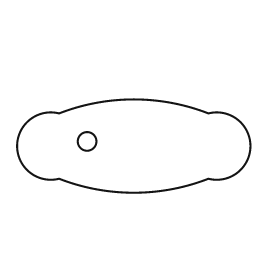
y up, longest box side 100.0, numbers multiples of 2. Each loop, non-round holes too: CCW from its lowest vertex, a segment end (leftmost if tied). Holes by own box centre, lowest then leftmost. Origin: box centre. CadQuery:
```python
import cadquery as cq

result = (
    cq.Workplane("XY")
    .moveTo(-32.0, -14.0)
    .threePointArc((0.0, -20.0), (32.0, -14.0))
    .threePointArc((50.0, 0.0), (32.0, 14.0))
    .threePointArc((0.0, 20.0), (-32.0, 14.0))
    .threePointArc((-50.0, 0.0), (-32.0, -14.0))
    .close()
    .moveTo(-20.0, 2.0)
    .circle(4.0)
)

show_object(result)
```